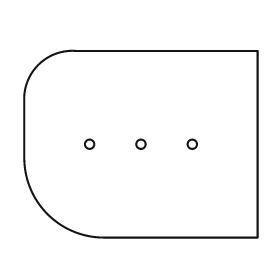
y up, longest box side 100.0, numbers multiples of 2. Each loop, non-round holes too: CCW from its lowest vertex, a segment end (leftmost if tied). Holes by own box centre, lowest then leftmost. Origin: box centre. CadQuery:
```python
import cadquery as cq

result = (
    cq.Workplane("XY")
    .moveTo(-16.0, -40.0)
    .lineTo(50.0, -40.0)
    .lineTo(50.0, 40.0)
    .lineTo(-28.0, 40.0)
    .threePointArc((-44.0, 34.0), (-50.0, 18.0))
    .lineTo(-50.0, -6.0)
    .threePointArc((-40.0, -30.0), (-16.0, -40.0))
    .close()
    .moveTo(-22.0, 0.0)
    .circle(2.0)
    .moveTo(0.0, 0.0)
    .circle(2.0)
    .moveTo(22.0, 0.0)
    .circle(2.0)
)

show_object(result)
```